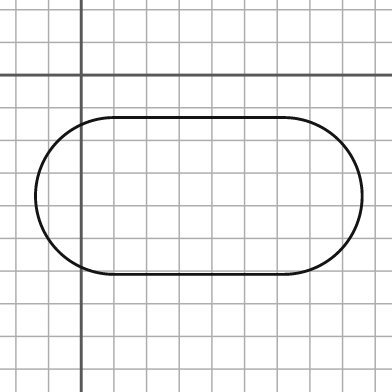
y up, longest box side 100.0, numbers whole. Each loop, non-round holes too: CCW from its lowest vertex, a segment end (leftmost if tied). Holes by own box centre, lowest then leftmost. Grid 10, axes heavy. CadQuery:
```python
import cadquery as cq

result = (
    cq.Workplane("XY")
    .moveTo(10.0, -61.0)
    .lineTo(62.0, -61.0)
    .threePointArc((86.0, -37.0), (62.0, -13.0))
    .lineTo(10.0, -13.0)
    .threePointArc((-14.0, -37.0), (10.0, -61.0))
    .close()
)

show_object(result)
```